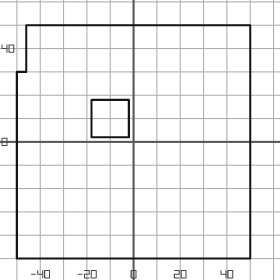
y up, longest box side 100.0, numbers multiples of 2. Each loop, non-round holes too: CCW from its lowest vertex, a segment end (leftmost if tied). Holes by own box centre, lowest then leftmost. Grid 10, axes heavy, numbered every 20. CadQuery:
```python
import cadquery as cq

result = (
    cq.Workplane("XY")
    .moveTo(-50.0, -50.0)
    .lineTo(50.0, -50.0)
    .lineTo(50.0, 50.0)
    .lineTo(-46.0, 50.0)
    .lineTo(-46.0, 30.0)
    .lineTo(-50.0, 30.0)
    .close()
    .moveTo(-18.0, 2.0)
    .lineTo(-2.0, 2.0)
    .lineTo(-2.0, 18.0)
    .lineTo(-18.0, 18.0)
    .close()
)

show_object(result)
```